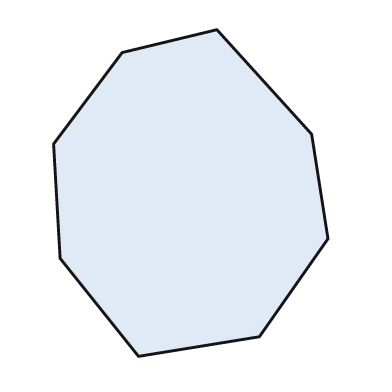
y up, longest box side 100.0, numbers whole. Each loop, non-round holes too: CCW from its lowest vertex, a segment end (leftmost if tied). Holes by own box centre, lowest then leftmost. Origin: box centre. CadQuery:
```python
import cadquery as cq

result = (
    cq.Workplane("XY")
    .moveTo(-16.0, -50.0)
    .lineTo(21.0, -44.0)
    .lineTo(42.0, -14.0)
    .lineTo(37.0, 18.0)
    .lineTo(8.0, 50.0)
    .lineTo(-21.0, 43.0)
    .lineTo(-42.0, 15.0)
    .lineTo(-40.0, -20.0)
    .close()
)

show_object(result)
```